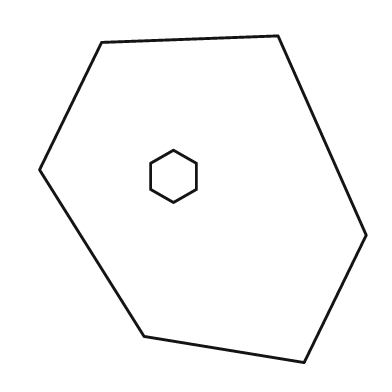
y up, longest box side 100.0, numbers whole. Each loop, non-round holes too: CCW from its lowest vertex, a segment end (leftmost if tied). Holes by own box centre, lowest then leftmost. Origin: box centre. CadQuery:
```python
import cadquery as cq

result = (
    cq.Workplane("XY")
    .moveTo(31.0, -50.0)
    .lineTo(50.0, -11.0)
    .lineTo(23.0, 50.0)
    .lineTo(-31.0, 48.0)
    .lineTo(-50.0, 9.0)
    .lineTo(-18.0, -42.0)
    .close()
    .moveTo(-9.0, -1.0)
    .lineTo(-2.0, 3.0)
    .lineTo(-2.0, 11.0)
    .lineTo(-9.0, 15.0)
    .lineTo(-16.0, 11.0)
    .lineTo(-16.0, 3.0)
    .close()
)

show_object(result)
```